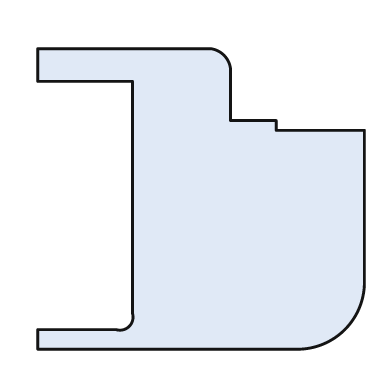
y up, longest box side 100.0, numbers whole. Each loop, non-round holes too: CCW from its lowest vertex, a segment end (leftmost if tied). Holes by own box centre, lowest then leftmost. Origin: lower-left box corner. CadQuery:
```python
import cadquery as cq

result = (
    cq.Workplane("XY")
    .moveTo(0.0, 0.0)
    .lineTo(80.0, 0.0)
    .threePointArc((94.0, 6.0), (100.0, 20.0))
    .lineTo(100.0, 67.0)
    .lineTo(73.0, 67.0)
    .lineTo(73.0, 70.0)
    .lineTo(59.0, 70.0)
    .lineTo(59.0, 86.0)
    .threePointArc((57.0, 90.0), (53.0, 92.0))
    .lineTo(0.0, 92.0)
    .lineTo(0.0, 82.0)
    .lineTo(29.0, 82.0)
    .lineTo(29.0, 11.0)
    .threePointArc((28.0, 7.0), (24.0, 6.0))
    .lineTo(0.0, 6.0)
    .close()
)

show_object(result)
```